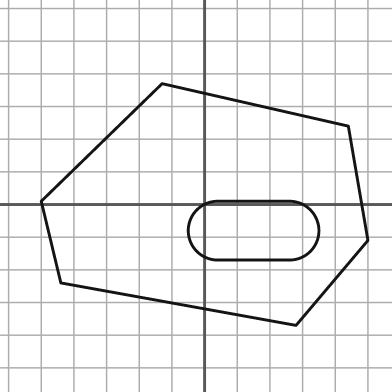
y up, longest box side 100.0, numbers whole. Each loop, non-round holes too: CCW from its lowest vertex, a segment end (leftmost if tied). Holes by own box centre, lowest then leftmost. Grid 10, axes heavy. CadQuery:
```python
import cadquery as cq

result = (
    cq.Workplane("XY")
    .moveTo(28.0, -37.0)
    .lineTo(50.0, -11.0)
    .lineTo(44.0, 24.0)
    .lineTo(-13.0, 37.0)
    .lineTo(-50.0, 1.0)
    .lineTo(-44.0, -24.0)
    .close()
    .moveTo(4.0, -17.0)
    .lineTo(26.0, -17.0)
    .threePointArc((35.0, -8.0), (26.0, 1.0))
    .lineTo(4.0, 1.0)
    .threePointArc((-5.0, -8.0), (4.0, -17.0))
    .close()
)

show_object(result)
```